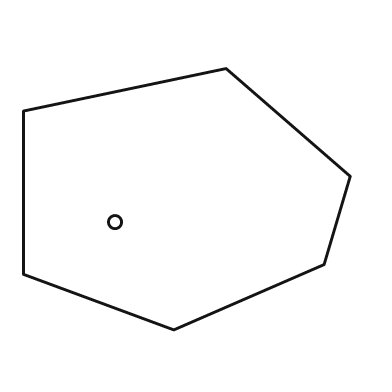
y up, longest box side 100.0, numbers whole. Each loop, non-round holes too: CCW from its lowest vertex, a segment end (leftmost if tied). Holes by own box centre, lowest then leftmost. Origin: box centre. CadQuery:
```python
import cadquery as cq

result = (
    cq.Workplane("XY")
    .moveTo(-4.0, -40.0)
    .lineTo(42.0, -20.0)
    .lineTo(50.0, 7.0)
    .lineTo(12.0, 40.0)
    .lineTo(-50.0, 27.0)
    .lineTo(-50.0, -23.0)
    .close()
    .moveTo(-22.0, -7.0)
    .circle(2.0)
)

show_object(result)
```